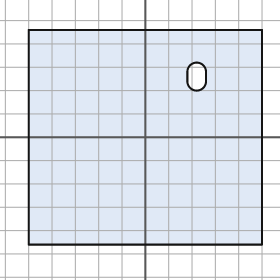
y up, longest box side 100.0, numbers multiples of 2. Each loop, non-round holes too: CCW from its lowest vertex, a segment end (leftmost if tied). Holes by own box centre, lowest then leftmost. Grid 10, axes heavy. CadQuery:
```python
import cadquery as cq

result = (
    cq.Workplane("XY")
    .moveTo(-50.0, -46.0)
    .lineTo(50.0, -46.0)
    .lineTo(50.0, 46.0)
    .lineTo(-50.0, 46.0)
    .close()
    .moveTo(18.0, 24.0)
    .threePointArc((22.0, 20.0), (26.0, 24.0))
    .lineTo(26.0, 28.0)
    .threePointArc((22.0, 32.0), (18.0, 28.0))
    .close()
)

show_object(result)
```